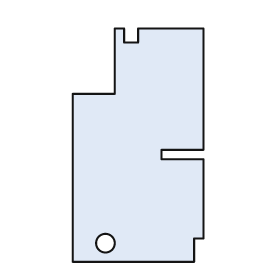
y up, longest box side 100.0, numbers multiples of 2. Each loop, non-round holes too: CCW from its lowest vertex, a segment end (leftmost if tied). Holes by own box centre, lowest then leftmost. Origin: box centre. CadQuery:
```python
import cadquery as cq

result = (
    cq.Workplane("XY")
    .moveTo(-28.0, -50.0)
    .lineTo(24.0, -50.0)
    .lineTo(24.0, -40.0)
    .lineTo(28.0, -40.0)
    .lineTo(28.0, -6.0)
    .lineTo(10.0, -6.0)
    .lineTo(10.0, -2.0)
    .lineTo(28.0, -2.0)
    .lineTo(28.0, 50.0)
    .lineTo(0.0, 50.0)
    .lineTo(0.0, 44.0)
    .lineTo(-6.0, 44.0)
    .lineTo(-6.0, 50.0)
    .lineTo(-10.0, 50.0)
    .lineTo(-10.0, 22.0)
    .lineTo(-28.0, 22.0)
    .close()
    .moveTo(-14.0, -42.0)
    .circle(4.0)
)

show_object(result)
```